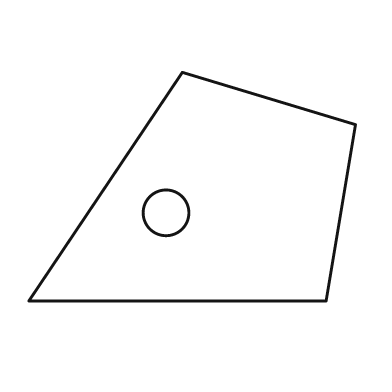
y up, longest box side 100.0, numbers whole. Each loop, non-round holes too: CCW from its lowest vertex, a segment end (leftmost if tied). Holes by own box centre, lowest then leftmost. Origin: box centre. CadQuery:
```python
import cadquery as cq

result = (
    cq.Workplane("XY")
    .moveTo(-50.0, -35.0)
    .lineTo(41.0, -35.0)
    .lineTo(50.0, 19.0)
    .lineTo(-3.0, 35.0)
    .close()
    .moveTo(-8.0, -8.0)
    .circle(7.0)
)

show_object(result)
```